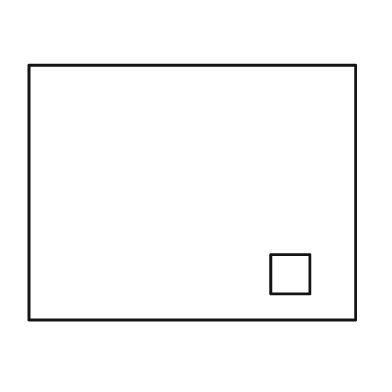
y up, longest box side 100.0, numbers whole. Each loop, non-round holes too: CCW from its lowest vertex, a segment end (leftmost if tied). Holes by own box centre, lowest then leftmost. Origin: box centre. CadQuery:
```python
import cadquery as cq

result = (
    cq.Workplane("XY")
    .moveTo(-50.0, -39.0)
    .lineTo(50.0, -39.0)
    .lineTo(50.0, 39.0)
    .lineTo(-50.0, 39.0)
    .close()
    .moveTo(24.0, -31.0)
    .lineTo(36.0, -31.0)
    .lineTo(36.0, -19.0)
    .lineTo(24.0, -19.0)
    .close()
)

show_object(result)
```